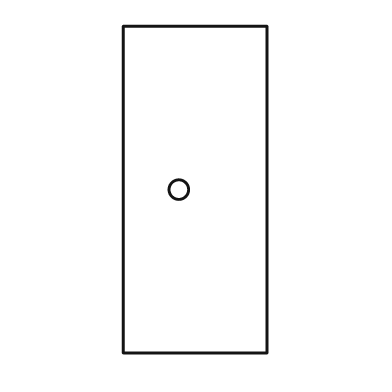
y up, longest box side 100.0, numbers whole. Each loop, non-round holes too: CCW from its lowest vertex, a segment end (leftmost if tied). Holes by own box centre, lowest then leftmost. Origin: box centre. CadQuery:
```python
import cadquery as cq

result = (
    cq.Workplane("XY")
    .moveTo(-22.0, -50.0)
    .lineTo(22.0, -50.0)
    .lineTo(22.0, 50.0)
    .lineTo(-22.0, 50.0)
    .close()
    .moveTo(-5.0, 0.0)
    .circle(3.0)
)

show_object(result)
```